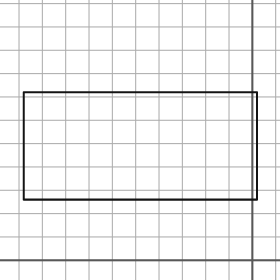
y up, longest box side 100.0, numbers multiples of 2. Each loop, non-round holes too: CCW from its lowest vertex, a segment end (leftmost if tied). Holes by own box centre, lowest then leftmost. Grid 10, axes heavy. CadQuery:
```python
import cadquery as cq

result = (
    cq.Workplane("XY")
    .moveTo(-98.0, 26.0)
    .lineTo(2.0, 26.0)
    .lineTo(2.0, 72.0)
    .lineTo(-98.0, 72.0)
    .close()
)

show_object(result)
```